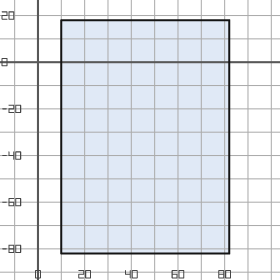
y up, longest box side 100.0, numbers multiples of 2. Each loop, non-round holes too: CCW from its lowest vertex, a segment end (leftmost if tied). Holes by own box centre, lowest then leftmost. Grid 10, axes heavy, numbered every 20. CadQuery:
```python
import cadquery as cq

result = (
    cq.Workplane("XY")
    .moveTo(10.0, -82.0)
    .lineTo(82.0, -82.0)
    .lineTo(82.0, 18.0)
    .lineTo(10.0, 18.0)
    .close()
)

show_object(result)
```